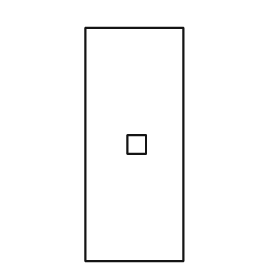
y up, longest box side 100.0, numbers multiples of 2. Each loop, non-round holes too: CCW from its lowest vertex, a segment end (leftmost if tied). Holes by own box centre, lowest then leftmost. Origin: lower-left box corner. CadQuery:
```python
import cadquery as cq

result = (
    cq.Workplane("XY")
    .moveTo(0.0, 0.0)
    .lineTo(42.0, 0.0)
    .lineTo(42.0, 100.0)
    .lineTo(0.0, 100.0)
    .close()
    .moveTo(18.0, 46.0)
    .lineTo(26.0, 46.0)
    .lineTo(26.0, 54.0)
    .lineTo(18.0, 54.0)
    .close()
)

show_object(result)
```